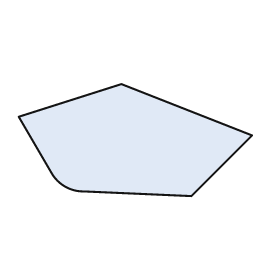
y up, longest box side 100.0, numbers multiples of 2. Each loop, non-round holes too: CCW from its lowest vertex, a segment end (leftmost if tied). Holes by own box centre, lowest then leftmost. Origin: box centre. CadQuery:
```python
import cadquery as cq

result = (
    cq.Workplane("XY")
    .moveTo(24.0, -24.0)
    .lineTo(50.0, 2.0)
    .lineTo(-6.0, 24.0)
    .lineTo(-50.0, 10.0)
    .lineTo(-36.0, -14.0)
    .threePointArc((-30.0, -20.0), (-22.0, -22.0))
    .close()
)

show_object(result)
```